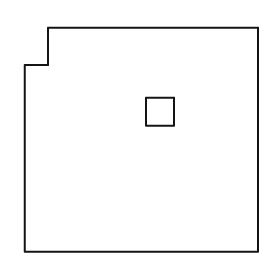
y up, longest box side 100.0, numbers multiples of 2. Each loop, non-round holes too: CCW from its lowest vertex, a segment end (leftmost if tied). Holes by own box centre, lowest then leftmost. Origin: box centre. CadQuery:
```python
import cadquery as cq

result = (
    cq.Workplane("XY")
    .moveTo(-50.0, -48.0)
    .lineTo(50.0, -48.0)
    .lineTo(50.0, 48.0)
    .lineTo(-40.0, 48.0)
    .lineTo(-40.0, 32.0)
    .lineTo(-50.0, 32.0)
    .close()
    .moveTo(2.0, 6.0)
    .lineTo(14.0, 6.0)
    .lineTo(14.0, 18.0)
    .lineTo(2.0, 18.0)
    .close()
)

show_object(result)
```